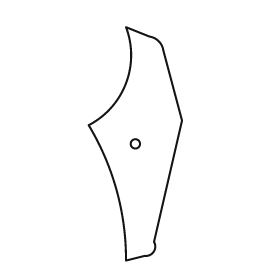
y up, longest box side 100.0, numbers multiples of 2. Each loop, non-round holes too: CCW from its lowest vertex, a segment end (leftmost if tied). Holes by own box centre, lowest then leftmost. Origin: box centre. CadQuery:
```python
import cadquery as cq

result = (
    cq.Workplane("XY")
    .moveTo(-4.0, -50.0)
    .lineTo(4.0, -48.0)
    .threePointArc((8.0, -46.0), (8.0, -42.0))
    .lineTo(20.0, 10.0)
    .lineTo(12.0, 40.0)
    .threePointArc((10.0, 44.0), (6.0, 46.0))
    .lineTo(-4.0, 50.0)
    .threePointArc((-4.0, 26.0), (-20.0, 8.0))
    .threePointArc((-8.0, -20.0), (-4.0, -50.0))
    .close()
    .moveTo(0.0, 0.0)
    .circle(2.0)
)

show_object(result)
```